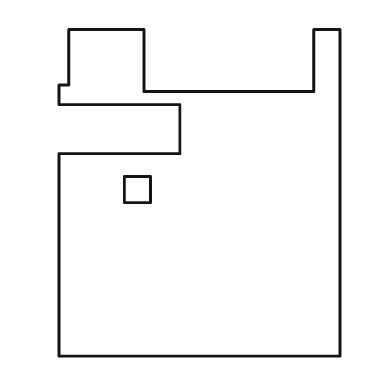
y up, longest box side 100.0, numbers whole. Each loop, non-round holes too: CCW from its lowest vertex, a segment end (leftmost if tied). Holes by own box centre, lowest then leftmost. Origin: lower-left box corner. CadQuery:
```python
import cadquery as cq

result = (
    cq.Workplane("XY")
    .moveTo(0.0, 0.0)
    .lineTo(86.0, 0.0)
    .lineTo(86.0, 100.0)
    .lineTo(78.0, 100.0)
    .lineTo(78.0, 81.0)
    .lineTo(26.0, 81.0)
    .lineTo(26.0, 100.0)
    .lineTo(3.0, 100.0)
    .lineTo(3.0, 83.0)
    .lineTo(0.0, 83.0)
    .lineTo(0.0, 77.0)
    .lineTo(37.0, 77.0)
    .lineTo(37.0, 62.0)
    .lineTo(0.0, 62.0)
    .close()
    .moveTo(20.0, 47.0)
    .lineTo(28.0, 47.0)
    .lineTo(28.0, 55.0)
    .lineTo(20.0, 55.0)
    .close()
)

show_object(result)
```